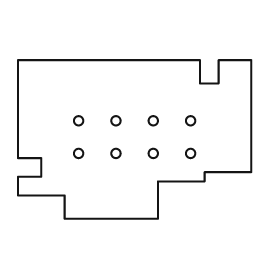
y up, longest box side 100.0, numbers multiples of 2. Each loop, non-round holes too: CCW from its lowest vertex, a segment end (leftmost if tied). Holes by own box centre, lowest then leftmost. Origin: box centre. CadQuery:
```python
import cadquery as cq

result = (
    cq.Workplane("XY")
    .moveTo(-30.0, -34.0)
    .lineTo(10.0, -34.0)
    .lineTo(10.0, -18.0)
    .lineTo(30.0, -18.0)
    .lineTo(30.0, -14.0)
    .lineTo(50.0, -14.0)
    .lineTo(50.0, 34.0)
    .lineTo(36.0, 34.0)
    .lineTo(36.0, 24.0)
    .lineTo(28.0, 24.0)
    .lineTo(28.0, 34.0)
    .lineTo(-50.0, 34.0)
    .lineTo(-50.0, -8.0)
    .lineTo(-40.0, -8.0)
    .lineTo(-40.0, -16.0)
    .lineTo(-50.0, -16.0)
    .lineTo(-50.0, -24.0)
    .lineTo(-30.0, -24.0)
    .close()
    .moveTo(-24.0, -6.0)
    .circle(2.0)
    .moveTo(-8.0, -6.0)
    .circle(2.0)
    .moveTo(8.0, -6.0)
    .circle(2.0)
    .moveTo(24.0, -6.0)
    .circle(2.0)
    .moveTo(-24.0, 8.0)
    .circle(2.0)
    .moveTo(-8.0, 8.0)
    .circle(2.0)
    .moveTo(8.0, 8.0)
    .circle(2.0)
    .moveTo(24.0, 8.0)
    .circle(2.0)
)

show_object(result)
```